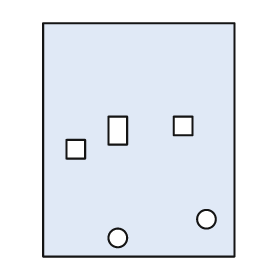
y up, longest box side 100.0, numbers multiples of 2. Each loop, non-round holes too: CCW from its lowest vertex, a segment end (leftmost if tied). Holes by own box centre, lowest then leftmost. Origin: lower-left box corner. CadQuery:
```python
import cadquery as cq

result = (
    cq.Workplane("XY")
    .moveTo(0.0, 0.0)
    .lineTo(82.0, 0.0)
    .lineTo(82.0, 100.0)
    .lineTo(0.0, 100.0)
    .close()
    .moveTo(32.0, 8.0)
    .circle(4.0)
    .moveTo(70.0, 16.0)
    .circle(4.0)
    .moveTo(10.0, 42.0)
    .lineTo(18.0, 42.0)
    .lineTo(18.0, 50.0)
    .lineTo(10.0, 50.0)
    .close()
    .moveTo(28.0, 48.0)
    .lineTo(36.0, 48.0)
    .lineTo(36.0, 60.0)
    .lineTo(28.0, 60.0)
    .close()
    .moveTo(56.0, 52.0)
    .lineTo(64.0, 52.0)
    .lineTo(64.0, 60.0)
    .lineTo(56.0, 60.0)
    .close()
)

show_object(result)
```